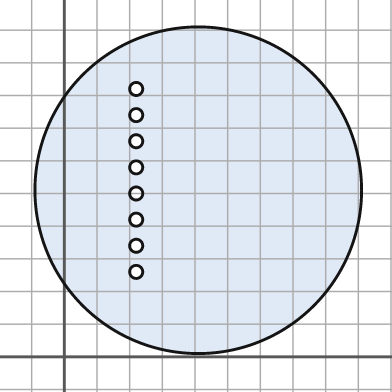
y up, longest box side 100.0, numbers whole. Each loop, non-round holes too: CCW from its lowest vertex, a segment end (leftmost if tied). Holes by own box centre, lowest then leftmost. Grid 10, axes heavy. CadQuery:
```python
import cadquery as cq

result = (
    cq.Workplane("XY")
    .moveTo(41.0, 51.0)
    .circle(50.0)
    .moveTo(22.0, 26.0)
    .circle(2.0)
    .moveTo(22.0, 34.0)
    .circle(2.0)
    .moveTo(22.0, 42.0)
    .circle(2.0)
    .moveTo(22.0, 50.0)
    .circle(2.0)
    .moveTo(22.0, 58.0)
    .circle(2.0)
    .moveTo(22.0, 66.0)
    .circle(2.0)
    .moveTo(22.0, 74.0)
    .circle(2.0)
    .moveTo(22.0, 82.0)
    .circle(2.0)
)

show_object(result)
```